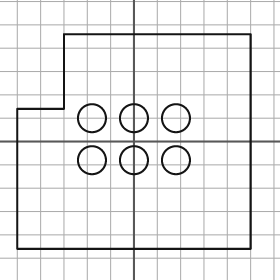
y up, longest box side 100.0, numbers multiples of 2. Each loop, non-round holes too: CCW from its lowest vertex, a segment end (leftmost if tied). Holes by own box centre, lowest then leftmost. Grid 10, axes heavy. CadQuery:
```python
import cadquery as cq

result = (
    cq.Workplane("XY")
    .moveTo(-50.0, -46.0)
    .lineTo(50.0, -46.0)
    .lineTo(50.0, 46.0)
    .lineTo(-30.0, 46.0)
    .lineTo(-30.0, 14.0)
    .lineTo(-50.0, 14.0)
    .close()
    .moveTo(-18.0, -8.0)
    .circle(6.0)
    .moveTo(0.0, -8.0)
    .circle(6.0)
    .moveTo(18.0, -8.0)
    .circle(6.0)
    .moveTo(-18.0, 10.0)
    .circle(6.0)
    .moveTo(0.0, 10.0)
    .circle(6.0)
    .moveTo(18.0, 10.0)
    .circle(6.0)
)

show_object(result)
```